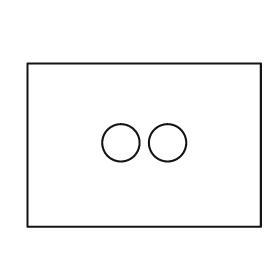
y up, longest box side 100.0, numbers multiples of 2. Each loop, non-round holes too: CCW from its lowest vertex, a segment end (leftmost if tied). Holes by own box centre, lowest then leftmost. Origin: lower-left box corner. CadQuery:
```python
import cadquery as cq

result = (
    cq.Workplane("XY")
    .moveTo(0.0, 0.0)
    .lineTo(100.0, 0.0)
    .lineTo(100.0, 70.0)
    .lineTo(0.0, 70.0)
    .close()
    .moveTo(40.0, 36.0)
    .circle(8.0)
    .moveTo(60.0, 36.0)
    .circle(8.0)
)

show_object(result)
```